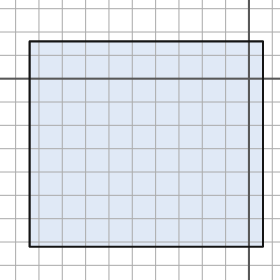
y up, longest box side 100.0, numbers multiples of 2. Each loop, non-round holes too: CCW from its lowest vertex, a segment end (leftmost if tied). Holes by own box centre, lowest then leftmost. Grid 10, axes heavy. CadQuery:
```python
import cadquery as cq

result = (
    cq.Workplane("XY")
    .moveTo(-94.0, -72.0)
    .lineTo(6.0, -72.0)
    .lineTo(6.0, 16.0)
    .lineTo(-94.0, 16.0)
    .close()
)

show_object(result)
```